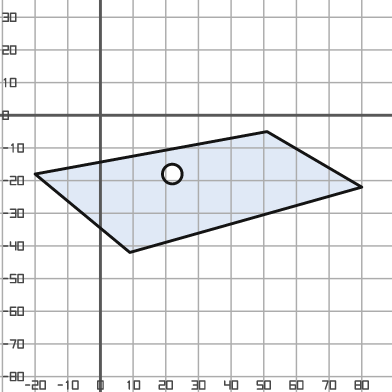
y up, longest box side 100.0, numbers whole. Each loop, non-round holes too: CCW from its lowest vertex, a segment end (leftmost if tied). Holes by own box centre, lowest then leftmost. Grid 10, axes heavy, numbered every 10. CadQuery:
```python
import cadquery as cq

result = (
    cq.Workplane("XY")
    .moveTo(9.0, -42.0)
    .lineTo(80.0, -22.0)
    .lineTo(51.0, -5.0)
    .lineTo(-20.0, -18.0)
    .close()
    .moveTo(22.0, -18.0)
    .circle(3.0)
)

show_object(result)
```